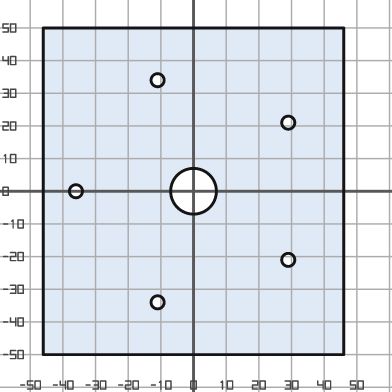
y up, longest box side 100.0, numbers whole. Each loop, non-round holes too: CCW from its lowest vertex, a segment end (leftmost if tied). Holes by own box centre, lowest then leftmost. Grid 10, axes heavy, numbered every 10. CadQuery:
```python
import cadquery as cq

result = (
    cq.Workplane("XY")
    .moveTo(-46.0, -50.0)
    .lineTo(46.0, -50.0)
    .lineTo(46.0, 50.0)
    .lineTo(-46.0, 50.0)
    .close()
    .moveTo(-11.0, -34.0)
    .circle(2.0)
    .moveTo(29.0, -21.0)
    .circle(2.0)
    .moveTo(-36.0, 0.0)
    .circle(2.0)
    .moveTo(0.0, 0.0)
    .circle(7.0)
    .moveTo(29.0, 21.0)
    .circle(2.0)
    .moveTo(-11.0, 34.0)
    .circle(2.0)
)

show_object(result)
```